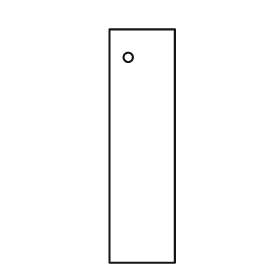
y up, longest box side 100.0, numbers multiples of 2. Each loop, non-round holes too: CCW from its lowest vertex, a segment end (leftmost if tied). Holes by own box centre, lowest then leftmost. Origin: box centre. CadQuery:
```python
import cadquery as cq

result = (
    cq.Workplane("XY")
    .moveTo(-14.0, -50.0)
    .lineTo(14.0, -50.0)
    .lineTo(14.0, 50.0)
    .lineTo(-14.0, 50.0)
    .close()
    .moveTo(-6.0, 38.0)
    .circle(2.0)
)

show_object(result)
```